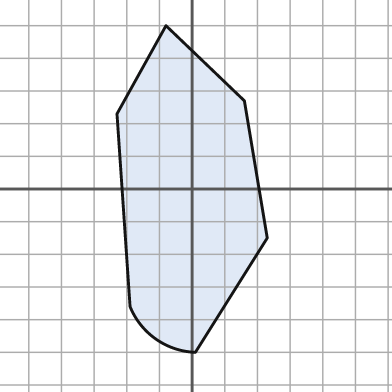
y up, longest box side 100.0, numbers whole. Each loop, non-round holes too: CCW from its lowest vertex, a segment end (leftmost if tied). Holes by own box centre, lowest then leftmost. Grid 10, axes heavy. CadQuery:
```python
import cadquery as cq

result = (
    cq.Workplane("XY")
    .moveTo(1.0, -50.0)
    .lineTo(23.0, -15.0)
    .lineTo(16.0, 27.0)
    .lineTo(-8.0, 50.0)
    .lineTo(-23.0, 23.0)
    .lineTo(-19.0, -36.0)
    .threePointArc((-11.0, -46.0), (1.0, -50.0))
    .close()
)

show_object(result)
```